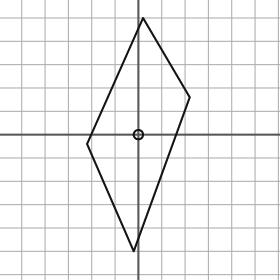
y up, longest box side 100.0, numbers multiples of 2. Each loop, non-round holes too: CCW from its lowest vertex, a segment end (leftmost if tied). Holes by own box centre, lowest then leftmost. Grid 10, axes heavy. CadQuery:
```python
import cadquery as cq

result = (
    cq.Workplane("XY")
    .moveTo(-2.0, -50.0)
    .lineTo(22.0, 16.0)
    .lineTo(2.0, 50.0)
    .lineTo(-22.0, -4.0)
    .close()
    .moveTo(0.0, 0.0)
    .circle(2.0)
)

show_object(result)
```